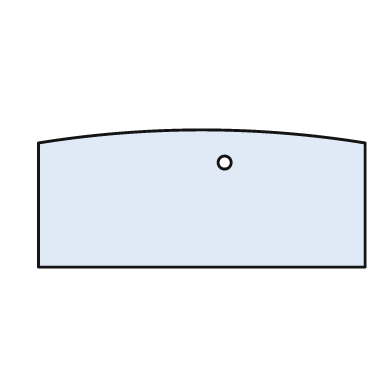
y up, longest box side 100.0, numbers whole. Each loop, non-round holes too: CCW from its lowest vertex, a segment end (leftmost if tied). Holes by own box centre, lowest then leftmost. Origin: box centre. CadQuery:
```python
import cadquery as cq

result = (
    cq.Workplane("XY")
    .moveTo(-50.0, -21.0)
    .lineTo(50.0, -21.0)
    .lineTo(50.0, 17.0)
    .threePointArc((0.0, 21.0), (-50.0, 17.0))
    .close()
    .moveTo(7.0, 11.0)
    .circle(2.0)
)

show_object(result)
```